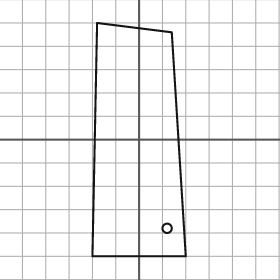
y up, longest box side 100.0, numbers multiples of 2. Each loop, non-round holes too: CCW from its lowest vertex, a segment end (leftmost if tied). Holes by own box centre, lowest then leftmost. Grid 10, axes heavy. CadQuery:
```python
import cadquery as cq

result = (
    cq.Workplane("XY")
    .moveTo(-20.0, -50.0)
    .lineTo(20.0, -50.0)
    .lineTo(14.0, 46.0)
    .lineTo(-18.0, 50.0)
    .close()
    .moveTo(12.0, -38.0)
    .circle(2.0)
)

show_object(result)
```